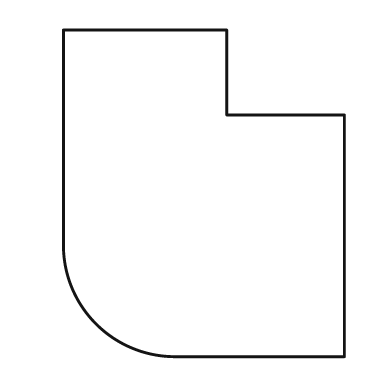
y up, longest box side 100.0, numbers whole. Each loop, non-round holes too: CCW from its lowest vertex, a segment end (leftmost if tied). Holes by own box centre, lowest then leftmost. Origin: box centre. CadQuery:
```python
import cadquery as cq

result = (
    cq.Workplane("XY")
    .moveTo(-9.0, -50.0)
    .lineTo(43.0, -50.0)
    .lineTo(43.0, 24.0)
    .lineTo(7.0, 24.0)
    .lineTo(7.0, 50.0)
    .lineTo(-43.0, 50.0)
    .lineTo(-43.0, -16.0)
    .threePointArc((-33.0, -40.0), (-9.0, -50.0))
    .close()
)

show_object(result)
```